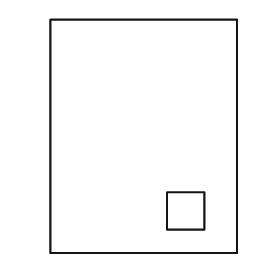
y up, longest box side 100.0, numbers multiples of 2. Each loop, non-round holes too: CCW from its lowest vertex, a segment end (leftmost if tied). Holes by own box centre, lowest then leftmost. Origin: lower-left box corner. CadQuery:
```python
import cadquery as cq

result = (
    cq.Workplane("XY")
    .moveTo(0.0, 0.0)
    .lineTo(80.0, 0.0)
    .lineTo(80.0, 100.0)
    .lineTo(0.0, 100.0)
    .close()
    .moveTo(50.0, 10.0)
    .lineTo(66.0, 10.0)
    .lineTo(66.0, 26.0)
    .lineTo(50.0, 26.0)
    .close()
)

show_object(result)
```